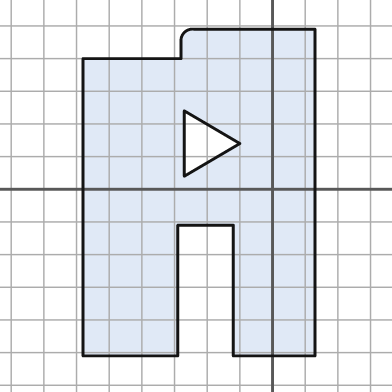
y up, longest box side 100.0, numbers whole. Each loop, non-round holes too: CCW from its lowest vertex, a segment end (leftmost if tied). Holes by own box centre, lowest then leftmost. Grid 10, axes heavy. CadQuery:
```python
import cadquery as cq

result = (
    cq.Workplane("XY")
    .moveTo(-58.0, -51.0)
    .lineTo(-29.0, -51.0)
    .lineTo(-29.0, -11.0)
    .lineTo(-12.0, -11.0)
    .lineTo(-12.0, -51.0)
    .lineTo(13.0, -51.0)
    .lineTo(13.0, 49.0)
    .lineTo(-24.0, 49.0)
    .threePointArc((-27.0, 48.0), (-28.0, 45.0))
    .lineTo(-28.0, 40.0)
    .lineTo(-58.0, 40.0)
    .close()
    .moveTo(-27.0, 4.0)
    .lineTo(-10.0, 14.0)
    .lineTo(-27.0, 24.0)
    .close()
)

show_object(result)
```